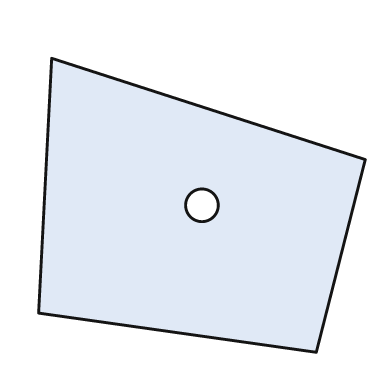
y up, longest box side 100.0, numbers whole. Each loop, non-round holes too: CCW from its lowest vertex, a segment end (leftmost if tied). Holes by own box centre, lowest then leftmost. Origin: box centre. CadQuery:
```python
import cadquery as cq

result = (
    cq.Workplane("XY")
    .moveTo(35.0, -45.0)
    .lineTo(50.0, 14.0)
    .lineTo(-46.0, 45.0)
    .lineTo(-50.0, -33.0)
    .close()
    .moveTo(0.0, 0.0)
    .circle(5.0)
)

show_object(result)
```